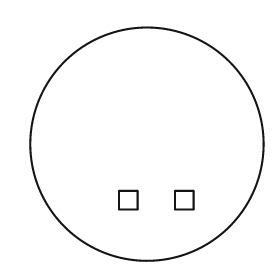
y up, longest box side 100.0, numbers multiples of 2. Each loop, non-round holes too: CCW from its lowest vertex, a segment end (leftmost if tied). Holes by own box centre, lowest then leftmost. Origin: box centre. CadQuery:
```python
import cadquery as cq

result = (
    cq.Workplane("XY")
    .moveTo(0.0, 0.0)
    .circle(50.0)
    .moveTo(-12.0, -28.0)
    .lineTo(-4.0, -28.0)
    .lineTo(-4.0, -20.0)
    .lineTo(-12.0, -20.0)
    .close()
    .moveTo(12.0, -28.0)
    .lineTo(20.0, -28.0)
    .lineTo(20.0, -20.0)
    .lineTo(12.0, -20.0)
    .close()
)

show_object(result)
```